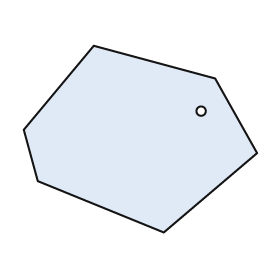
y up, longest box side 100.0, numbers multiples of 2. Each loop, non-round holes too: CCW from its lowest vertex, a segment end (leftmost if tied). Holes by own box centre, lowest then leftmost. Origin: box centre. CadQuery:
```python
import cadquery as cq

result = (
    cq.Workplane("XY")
    .moveTo(10.0, -40.0)
    .lineTo(50.0, -6.0)
    .lineTo(32.0, 26.0)
    .lineTo(-20.0, 40.0)
    .lineTo(-50.0, 4.0)
    .lineTo(-44.0, -18.0)
    .close()
    .moveTo(26.0, 12.0)
    .circle(2.0)
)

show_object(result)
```